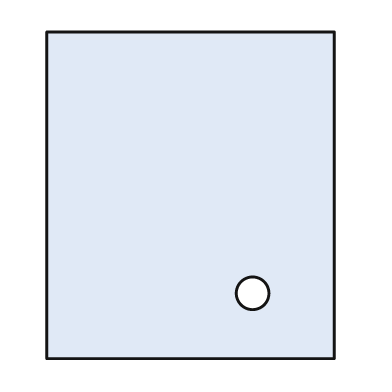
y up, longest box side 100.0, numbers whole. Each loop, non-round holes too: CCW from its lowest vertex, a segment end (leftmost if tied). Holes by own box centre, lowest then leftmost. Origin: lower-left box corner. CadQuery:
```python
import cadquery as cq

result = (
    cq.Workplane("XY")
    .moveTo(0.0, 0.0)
    .lineTo(88.0, 0.0)
    .lineTo(88.0, 100.0)
    .lineTo(0.0, 100.0)
    .close()
    .moveTo(63.0, 20.0)
    .circle(5.0)
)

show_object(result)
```